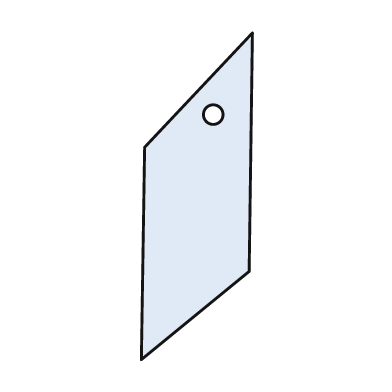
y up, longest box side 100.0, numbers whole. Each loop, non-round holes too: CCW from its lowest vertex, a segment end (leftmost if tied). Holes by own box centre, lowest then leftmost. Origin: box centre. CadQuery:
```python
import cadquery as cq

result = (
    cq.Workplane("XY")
    .moveTo(-17.0, -50.0)
    .lineTo(16.0, -23.0)
    .lineTo(17.0, 50.0)
    .lineTo(-16.0, 15.0)
    .close()
    .moveTo(5.0, 25.0)
    .circle(3.0)
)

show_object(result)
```